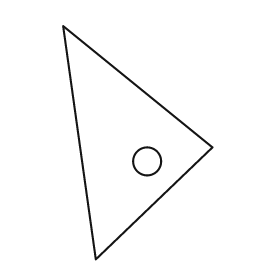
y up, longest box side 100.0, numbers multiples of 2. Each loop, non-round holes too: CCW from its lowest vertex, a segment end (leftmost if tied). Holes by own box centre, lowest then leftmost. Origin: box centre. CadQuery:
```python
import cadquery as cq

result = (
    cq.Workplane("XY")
    .moveTo(-18.0, -50.0)
    .lineTo(32.0, -2.0)
    .lineTo(-32.0, 50.0)
    .close()
    .moveTo(4.0, -8.0)
    .circle(6.0)
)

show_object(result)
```